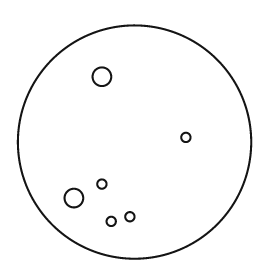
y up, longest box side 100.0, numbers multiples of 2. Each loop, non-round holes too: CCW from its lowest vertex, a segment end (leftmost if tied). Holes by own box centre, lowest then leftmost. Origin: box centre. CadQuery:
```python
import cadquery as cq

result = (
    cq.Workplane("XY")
    .moveTo(0.0, 0.0)
    .circle(50.0)
    .moveTo(-10.0, -34.0)
    .circle(2.0)
    .moveTo(-2.0, -32.0)
    .circle(2.0)
    .moveTo(-26.0, -24.0)
    .circle(4.0)
    .moveTo(-14.0, -18.0)
    .circle(2.0)
    .moveTo(22.0, 2.0)
    .circle(2.0)
    .moveTo(-14.0, 28.0)
    .circle(4.0)
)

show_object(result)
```